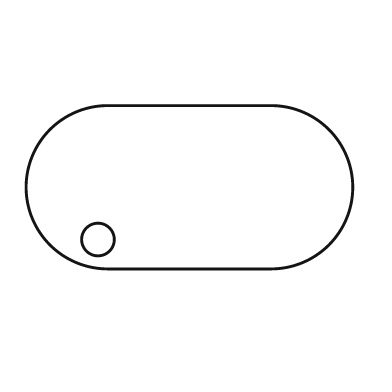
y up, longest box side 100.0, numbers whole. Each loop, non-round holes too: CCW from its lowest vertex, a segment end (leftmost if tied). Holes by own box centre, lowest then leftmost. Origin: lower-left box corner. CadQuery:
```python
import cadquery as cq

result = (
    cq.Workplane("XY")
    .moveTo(25.0, 0.0)
    .lineTo(75.0, 0.0)
    .threePointArc((100.0, 25.0), (75.0, 50.0))
    .lineTo(25.0, 50.0)
    .threePointArc((0.0, 25.0), (25.0, 0.0))
    .close()
    .moveTo(22.0, 9.0)
    .circle(5.0)
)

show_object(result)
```